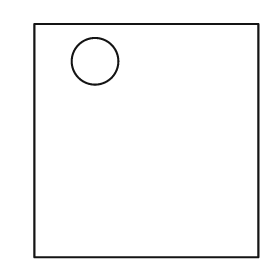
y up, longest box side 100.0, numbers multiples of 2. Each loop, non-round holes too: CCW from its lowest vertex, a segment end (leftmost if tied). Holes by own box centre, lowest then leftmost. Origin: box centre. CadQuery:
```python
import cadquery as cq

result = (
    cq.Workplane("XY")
    .moveTo(-48.0, -50.0)
    .lineTo(48.0, -50.0)
    .lineTo(48.0, 50.0)
    .lineTo(-48.0, 50.0)
    .close()
    .moveTo(-22.0, 34.0)
    .circle(10.0)
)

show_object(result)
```